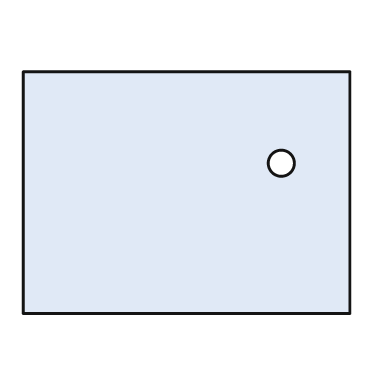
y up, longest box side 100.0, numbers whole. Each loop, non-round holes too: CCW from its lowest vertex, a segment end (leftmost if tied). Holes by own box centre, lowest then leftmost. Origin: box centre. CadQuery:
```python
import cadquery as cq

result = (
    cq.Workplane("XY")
    .moveTo(-50.0, -37.0)
    .lineTo(50.0, -37.0)
    .lineTo(50.0, 37.0)
    .lineTo(-50.0, 37.0)
    .close()
    .moveTo(29.0, 9.0)
    .circle(4.0)
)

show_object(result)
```